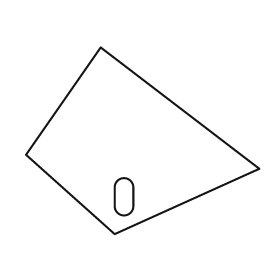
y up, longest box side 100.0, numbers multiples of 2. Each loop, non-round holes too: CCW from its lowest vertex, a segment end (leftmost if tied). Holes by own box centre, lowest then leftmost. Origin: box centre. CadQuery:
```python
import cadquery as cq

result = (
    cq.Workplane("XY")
    .moveTo(-12.0, -40.0)
    .lineTo(50.0, -12.0)
    .lineTo(-18.0, 40.0)
    .lineTo(-50.0, -6.0)
    .close()
    .moveTo(-12.0, -28.0)
    .threePointArc((-8.0, -32.0), (-4.0, -28.0))
    .lineTo(-4.0, -20.0)
    .threePointArc((-8.0, -16.0), (-12.0, -20.0))
    .close()
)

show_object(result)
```